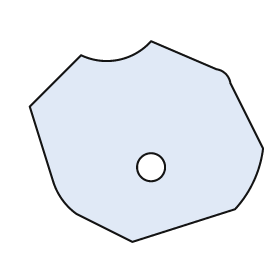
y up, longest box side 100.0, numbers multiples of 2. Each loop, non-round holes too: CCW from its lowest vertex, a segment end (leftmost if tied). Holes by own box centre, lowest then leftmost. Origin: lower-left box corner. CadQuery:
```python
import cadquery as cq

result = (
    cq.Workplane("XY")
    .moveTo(44.0, 0.0)
    .lineTo(88.0, 14.0)
    .threePointArc((96.0, 26.0), (100.0, 40.0))
    .lineTo(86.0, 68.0)
    .threePointArc((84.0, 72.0), (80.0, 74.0))
    .lineTo(52.0, 86.0)
    .threePointArc((38.0, 78.0), (22.0, 80.0))
    .lineTo(0.0, 58.0)
    .lineTo(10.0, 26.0)
    .threePointArc((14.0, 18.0), (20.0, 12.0))
    .close()
    .moveTo(52.0, 32.0)
    .circle(6.0)
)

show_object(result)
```